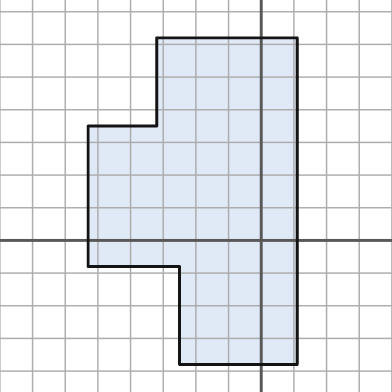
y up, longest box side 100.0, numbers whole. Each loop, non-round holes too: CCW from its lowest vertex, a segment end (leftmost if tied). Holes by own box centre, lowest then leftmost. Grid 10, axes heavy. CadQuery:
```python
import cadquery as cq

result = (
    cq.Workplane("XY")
    .moveTo(-25.0, -38.0)
    .lineTo(11.0, -38.0)
    .lineTo(11.0, 62.0)
    .lineTo(-32.0, 62.0)
    .lineTo(-32.0, 35.0)
    .lineTo(-53.0, 35.0)
    .lineTo(-53.0, -8.0)
    .lineTo(-25.0, -8.0)
    .close()
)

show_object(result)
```